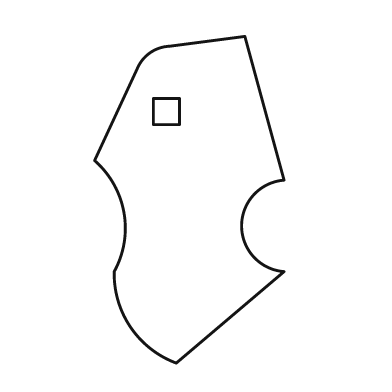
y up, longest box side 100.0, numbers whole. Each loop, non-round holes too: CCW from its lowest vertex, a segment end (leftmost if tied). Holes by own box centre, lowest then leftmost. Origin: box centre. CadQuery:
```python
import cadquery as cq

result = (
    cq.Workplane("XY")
    .moveTo(-4.0, -50.0)
    .lineTo(29.0, -22.0)
    .threePointArc((16.0, -8.0), (29.0, 6.0))
    .lineTo(17.0, 50.0)
    .lineTo(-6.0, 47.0)
    .threePointArc((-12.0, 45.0), (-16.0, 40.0))
    .lineTo(-29.0, 12.0)
    .threePointArc((-20.0, -4.0), (-23.0, -22.0))
    .threePointArc((-18.0, -39.0), (-4.0, -50.0))
    .close()
    .moveTo(-11.0, 23.0)
    .lineTo(-3.0, 23.0)
    .lineTo(-3.0, 31.0)
    .lineTo(-11.0, 31.0)
    .close()
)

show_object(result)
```